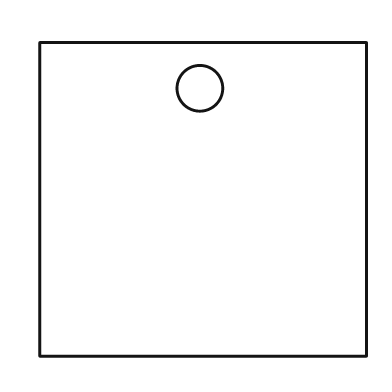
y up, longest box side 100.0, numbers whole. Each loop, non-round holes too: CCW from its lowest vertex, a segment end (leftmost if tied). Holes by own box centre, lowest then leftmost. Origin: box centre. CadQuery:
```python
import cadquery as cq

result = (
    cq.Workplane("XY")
    .moveTo(-50.0, -48.0)
    .lineTo(50.0, -48.0)
    .lineTo(50.0, 48.0)
    .lineTo(-50.0, 48.0)
    .close()
    .moveTo(-1.0, 34.0)
    .circle(7.0)
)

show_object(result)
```